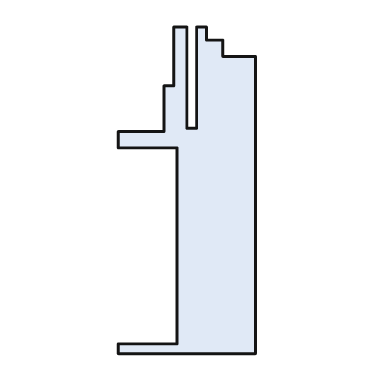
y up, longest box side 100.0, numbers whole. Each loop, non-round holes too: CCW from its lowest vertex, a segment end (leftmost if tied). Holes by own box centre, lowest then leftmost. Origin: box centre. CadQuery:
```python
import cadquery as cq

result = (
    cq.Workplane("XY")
    .moveTo(-21.0, -50.0)
    .lineTo(21.0, -50.0)
    .lineTo(21.0, 41.0)
    .lineTo(11.0, 41.0)
    .lineTo(11.0, 46.0)
    .lineTo(6.0, 46.0)
    .lineTo(6.0, 50.0)
    .lineTo(3.0, 50.0)
    .lineTo(3.0, 19.0)
    .lineTo(0.0, 19.0)
    .lineTo(0.0, 50.0)
    .lineTo(-4.0, 50.0)
    .lineTo(-4.0, 32.0)
    .lineTo(-7.0, 32.0)
    .lineTo(-7.0, 18.0)
    .lineTo(-21.0, 18.0)
    .lineTo(-21.0, 13.0)
    .lineTo(-3.0, 13.0)
    .lineTo(-3.0, -47.0)
    .lineTo(-21.0, -47.0)
    .close()
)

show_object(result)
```